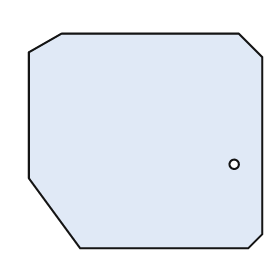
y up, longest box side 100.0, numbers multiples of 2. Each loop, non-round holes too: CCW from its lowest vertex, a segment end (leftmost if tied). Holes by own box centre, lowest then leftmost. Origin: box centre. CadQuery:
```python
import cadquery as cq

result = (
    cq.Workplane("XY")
    .moveTo(-28.0, -46.0)
    .lineTo(44.0, -46.0)
    .lineTo(50.0, -40.0)
    .lineTo(50.0, 36.0)
    .lineTo(40.0, 46.0)
    .lineTo(-36.0, 46.0)
    .lineTo(-50.0, 38.0)
    .lineTo(-50.0, -16.0)
    .close()
    .moveTo(38.0, -10.0)
    .circle(2.0)
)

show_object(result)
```